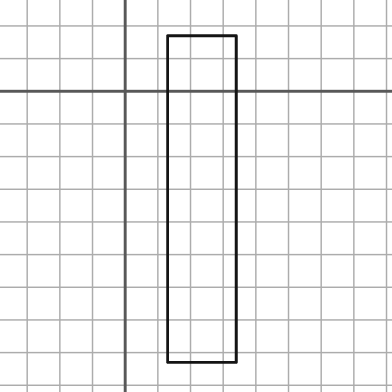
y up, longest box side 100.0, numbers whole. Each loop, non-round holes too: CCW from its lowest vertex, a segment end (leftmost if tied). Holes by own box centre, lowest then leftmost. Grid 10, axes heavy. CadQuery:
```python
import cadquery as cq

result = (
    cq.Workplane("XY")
    .moveTo(13.0, -83.0)
    .lineTo(34.0, -83.0)
    .lineTo(34.0, 17.0)
    .lineTo(13.0, 17.0)
    .close()
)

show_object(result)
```